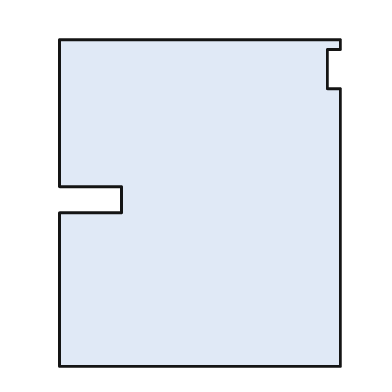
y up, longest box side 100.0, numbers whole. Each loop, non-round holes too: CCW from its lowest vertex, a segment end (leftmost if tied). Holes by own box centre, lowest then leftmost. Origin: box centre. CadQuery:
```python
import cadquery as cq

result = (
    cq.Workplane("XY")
    .moveTo(-43.0, -50.0)
    .lineTo(43.0, -50.0)
    .lineTo(43.0, 35.0)
    .lineTo(39.0, 35.0)
    .lineTo(39.0, 47.0)
    .lineTo(43.0, 47.0)
    .lineTo(43.0, 50.0)
    .lineTo(-43.0, 50.0)
    .lineTo(-43.0, 5.0)
    .lineTo(-24.0, 5.0)
    .lineTo(-24.0, -3.0)
    .lineTo(-43.0, -3.0)
    .close()
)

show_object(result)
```